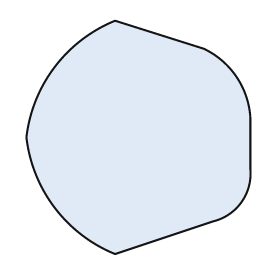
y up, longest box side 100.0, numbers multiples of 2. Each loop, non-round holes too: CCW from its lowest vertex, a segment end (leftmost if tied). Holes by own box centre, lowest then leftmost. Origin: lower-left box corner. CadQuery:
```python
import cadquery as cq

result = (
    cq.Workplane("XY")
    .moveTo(38.0, 0.0)
    .lineTo(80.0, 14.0)
    .threePointArc((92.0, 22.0), (96.0, 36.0))
    .lineTo(96.0, 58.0)
    .threePointArc((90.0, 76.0), (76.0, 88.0))
    .lineTo(38.0, 100.0)
    .threePointArc((12.0, 80.0), (0.0, 50.0))
    .threePointArc((12.0, 20.0), (38.0, 0.0))
    .close()
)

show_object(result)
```